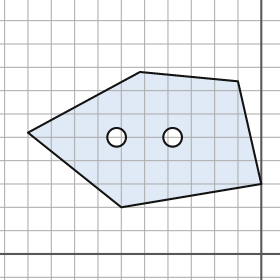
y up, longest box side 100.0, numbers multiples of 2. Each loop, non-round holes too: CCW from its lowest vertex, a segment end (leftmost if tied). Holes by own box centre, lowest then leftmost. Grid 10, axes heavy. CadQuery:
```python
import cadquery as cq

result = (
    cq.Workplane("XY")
    .moveTo(-60.0, 20.0)
    .lineTo(0.0, 30.0)
    .lineTo(-10.0, 74.0)
    .lineTo(-52.0, 78.0)
    .lineTo(-100.0, 52.0)
    .close()
    .moveTo(-62.0, 50.0)
    .circle(4.0)
    .moveTo(-38.0, 50.0)
    .circle(4.0)
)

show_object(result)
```